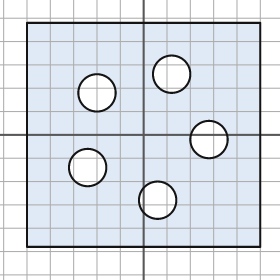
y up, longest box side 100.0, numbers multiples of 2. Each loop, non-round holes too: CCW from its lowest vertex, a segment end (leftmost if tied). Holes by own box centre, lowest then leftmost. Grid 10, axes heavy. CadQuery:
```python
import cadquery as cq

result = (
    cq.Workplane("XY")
    .moveTo(-50.0, -48.0)
    .lineTo(50.0, -48.0)
    .lineTo(50.0, 48.0)
    .lineTo(-50.0, 48.0)
    .close()
    .moveTo(6.0, -28.0)
    .circle(8.0)
    .moveTo(-24.0, -14.0)
    .circle(8.0)
    .moveTo(28.0, -2.0)
    .circle(8.0)
    .moveTo(-20.0, 18.0)
    .circle(8.0)
    .moveTo(12.0, 26.0)
    .circle(8.0)
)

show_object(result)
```